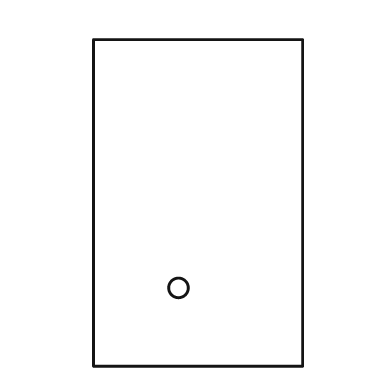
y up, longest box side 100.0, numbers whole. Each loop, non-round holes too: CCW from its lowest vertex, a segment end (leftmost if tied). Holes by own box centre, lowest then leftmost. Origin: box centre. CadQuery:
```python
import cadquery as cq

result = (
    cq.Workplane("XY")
    .moveTo(-32.0, -50.0)
    .lineTo(32.0, -50.0)
    .lineTo(32.0, 50.0)
    .lineTo(-32.0, 50.0)
    .close()
    .moveTo(-6.0, -26.0)
    .circle(3.0)
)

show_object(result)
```